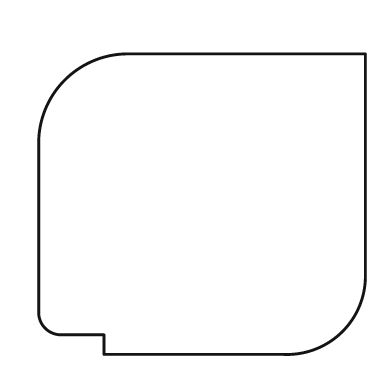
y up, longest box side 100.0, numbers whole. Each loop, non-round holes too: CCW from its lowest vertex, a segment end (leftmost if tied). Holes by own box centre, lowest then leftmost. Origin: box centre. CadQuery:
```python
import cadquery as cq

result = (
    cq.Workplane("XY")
    .moveTo(-30.0, -46.0)
    .lineTo(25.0, -46.0)
    .threePointArc((43.0, -39.0), (50.0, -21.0))
    .lineTo(50.0, 46.0)
    .lineTo(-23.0, 46.0)
    .threePointArc((-42.0, 38.0), (-50.0, 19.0))
    .lineTo(-50.0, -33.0)
    .threePointArc((-48.0, -38.0), (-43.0, -40.0))
    .lineTo(-30.0, -40.0)
    .close()
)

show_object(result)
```